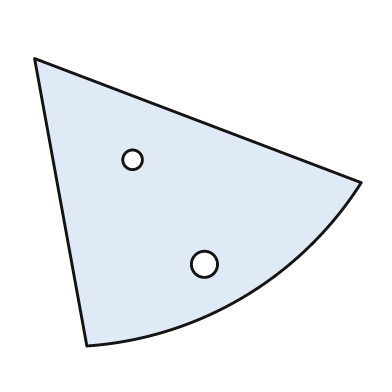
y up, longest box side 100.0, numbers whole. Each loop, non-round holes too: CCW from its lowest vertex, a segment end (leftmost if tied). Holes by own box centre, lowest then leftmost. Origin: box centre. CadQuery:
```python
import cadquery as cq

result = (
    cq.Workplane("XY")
    .moveTo(-34.0, -44.0)
    .threePointArc((14.0, -29.0), (50.0, 6.0))
    .lineTo(-50.0, 44.0)
    .close()
    .moveTo(2.0, -19.0)
    .circle(4.0)
    .moveTo(-20.0, 13.0)
    .circle(3.0)
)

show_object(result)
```